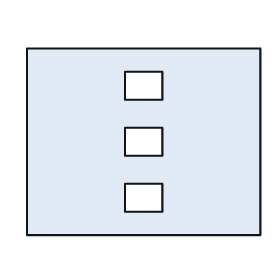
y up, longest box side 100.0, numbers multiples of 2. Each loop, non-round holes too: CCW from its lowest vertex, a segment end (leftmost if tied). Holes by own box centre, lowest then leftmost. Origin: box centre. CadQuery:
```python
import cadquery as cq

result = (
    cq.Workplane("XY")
    .moveTo(-50.0, -40.0)
    .lineTo(50.0, -40.0)
    .lineTo(50.0, 40.0)
    .lineTo(-50.0, 40.0)
    .close()
    .moveTo(-8.0, -30.0)
    .lineTo(8.0, -30.0)
    .lineTo(8.0, -18.0)
    .lineTo(-8.0, -18.0)
    .close()
    .moveTo(-8.0, -6.0)
    .lineTo(8.0, -6.0)
    .lineTo(8.0, 6.0)
    .lineTo(-8.0, 6.0)
    .close()
    .moveTo(-8.0, 18.0)
    .lineTo(8.0, 18.0)
    .lineTo(8.0, 30.0)
    .lineTo(-8.0, 30.0)
    .close()
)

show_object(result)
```